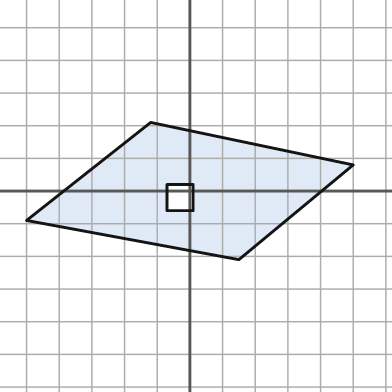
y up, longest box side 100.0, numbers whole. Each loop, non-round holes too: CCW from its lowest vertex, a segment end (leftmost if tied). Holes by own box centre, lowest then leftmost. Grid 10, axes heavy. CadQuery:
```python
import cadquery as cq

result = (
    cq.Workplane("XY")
    .moveTo(15.0, -21.0)
    .lineTo(50.0, 8.0)
    .lineTo(-12.0, 21.0)
    .lineTo(-50.0, -9.0)
    .close()
    .moveTo(-7.0, -6.0)
    .lineTo(1.0, -6.0)
    .lineTo(1.0, 2.0)
    .lineTo(-7.0, 2.0)
    .close()
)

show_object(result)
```